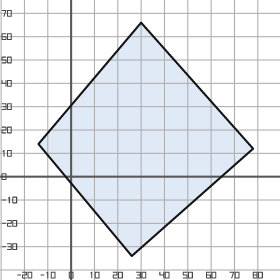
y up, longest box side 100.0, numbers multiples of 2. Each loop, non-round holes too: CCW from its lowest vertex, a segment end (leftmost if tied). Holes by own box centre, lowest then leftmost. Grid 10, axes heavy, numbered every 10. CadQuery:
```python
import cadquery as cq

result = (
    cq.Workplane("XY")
    .moveTo(26.0, -34.0)
    .lineTo(78.0, 12.0)
    .lineTo(30.0, 66.0)
    .lineTo(-14.0, 14.0)
    .close()
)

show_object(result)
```